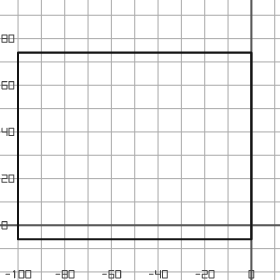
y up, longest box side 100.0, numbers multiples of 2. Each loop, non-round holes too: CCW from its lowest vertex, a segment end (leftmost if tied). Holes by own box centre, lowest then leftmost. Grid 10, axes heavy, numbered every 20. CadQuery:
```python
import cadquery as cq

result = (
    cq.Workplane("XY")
    .moveTo(-100.0, -6.0)
    .lineTo(0.0, -6.0)
    .lineTo(0.0, 74.0)
    .lineTo(-100.0, 74.0)
    .close()
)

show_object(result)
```